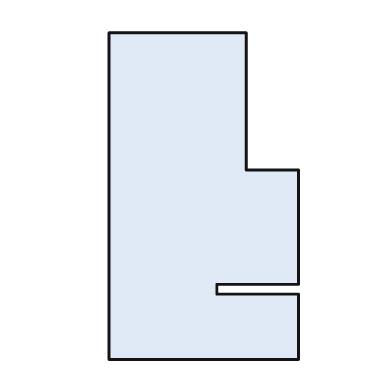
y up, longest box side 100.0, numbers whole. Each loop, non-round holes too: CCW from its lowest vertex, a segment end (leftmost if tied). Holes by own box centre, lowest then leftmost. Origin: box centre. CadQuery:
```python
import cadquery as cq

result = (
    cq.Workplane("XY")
    .moveTo(-29.0, -50.0)
    .lineTo(29.0, -50.0)
    .lineTo(29.0, -30.0)
    .lineTo(4.0, -30.0)
    .lineTo(4.0, -27.0)
    .lineTo(29.0, -27.0)
    .lineTo(29.0, 8.0)
    .lineTo(13.0, 8.0)
    .lineTo(13.0, 50.0)
    .lineTo(-29.0, 50.0)
    .close()
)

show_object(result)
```